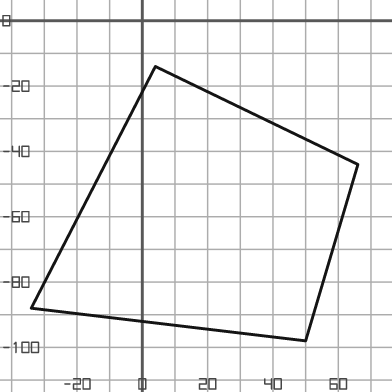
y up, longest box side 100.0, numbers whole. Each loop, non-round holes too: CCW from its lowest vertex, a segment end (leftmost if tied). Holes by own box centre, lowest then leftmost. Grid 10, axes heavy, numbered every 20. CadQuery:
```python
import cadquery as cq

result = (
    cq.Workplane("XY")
    .moveTo(50.0, -98.0)
    .lineTo(66.0, -44.0)
    .lineTo(4.0, -14.0)
    .lineTo(-34.0, -88.0)
    .close()
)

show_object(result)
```